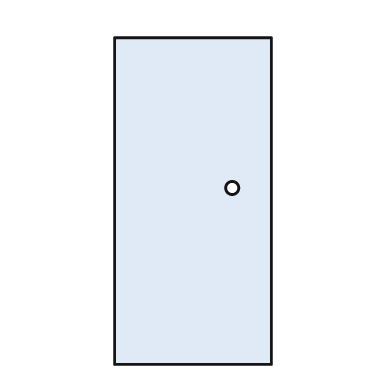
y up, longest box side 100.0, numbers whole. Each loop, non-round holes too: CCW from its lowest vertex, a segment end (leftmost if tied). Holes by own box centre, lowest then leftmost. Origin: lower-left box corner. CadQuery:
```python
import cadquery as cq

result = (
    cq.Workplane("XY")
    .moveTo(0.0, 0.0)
    .lineTo(48.0, 0.0)
    .lineTo(48.0, 100.0)
    .lineTo(0.0, 100.0)
    .close()
    .moveTo(36.0, 54.0)
    .circle(2.0)
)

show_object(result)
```